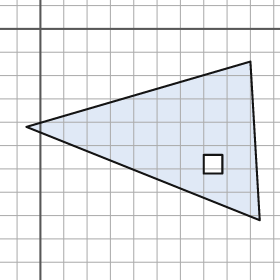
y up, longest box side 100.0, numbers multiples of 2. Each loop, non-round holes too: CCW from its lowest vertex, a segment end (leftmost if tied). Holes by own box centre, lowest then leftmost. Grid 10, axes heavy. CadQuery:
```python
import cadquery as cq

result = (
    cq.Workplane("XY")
    .moveTo(94.0, -82.0)
    .lineTo(90.0, -14.0)
    .lineTo(-6.0, -42.0)
    .close()
    .moveTo(70.0, -62.0)
    .lineTo(78.0, -62.0)
    .lineTo(78.0, -54.0)
    .lineTo(70.0, -54.0)
    .close()
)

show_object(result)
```